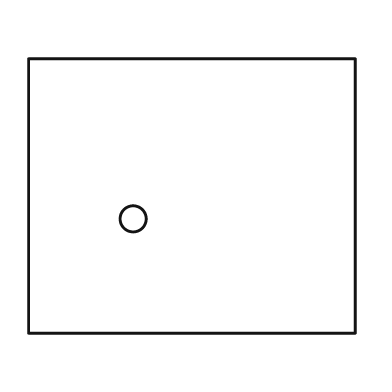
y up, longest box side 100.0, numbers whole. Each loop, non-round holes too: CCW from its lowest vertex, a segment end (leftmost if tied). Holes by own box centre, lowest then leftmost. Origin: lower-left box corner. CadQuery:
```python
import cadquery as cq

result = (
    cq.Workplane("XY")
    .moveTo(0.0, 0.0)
    .lineTo(100.0, 0.0)
    .lineTo(100.0, 84.0)
    .lineTo(0.0, 84.0)
    .close()
    .moveTo(32.0, 35.0)
    .circle(4.0)
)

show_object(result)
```